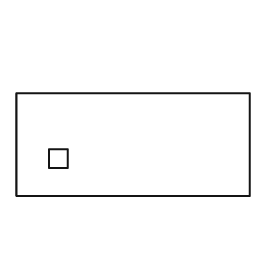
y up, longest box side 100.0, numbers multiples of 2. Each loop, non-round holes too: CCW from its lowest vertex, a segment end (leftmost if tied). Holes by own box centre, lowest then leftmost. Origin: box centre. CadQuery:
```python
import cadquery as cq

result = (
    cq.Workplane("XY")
    .moveTo(-50.0, -22.0)
    .lineTo(50.0, -22.0)
    .lineTo(50.0, 22.0)
    .lineTo(-50.0, 22.0)
    .close()
    .moveTo(-36.0, -10.0)
    .lineTo(-28.0, -10.0)
    .lineTo(-28.0, -2.0)
    .lineTo(-36.0, -2.0)
    .close()
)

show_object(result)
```